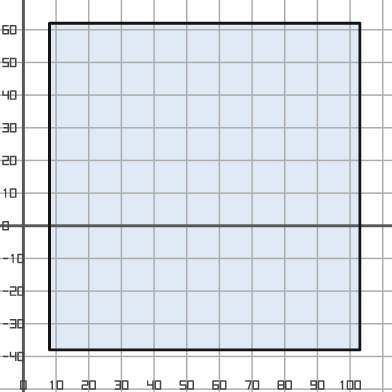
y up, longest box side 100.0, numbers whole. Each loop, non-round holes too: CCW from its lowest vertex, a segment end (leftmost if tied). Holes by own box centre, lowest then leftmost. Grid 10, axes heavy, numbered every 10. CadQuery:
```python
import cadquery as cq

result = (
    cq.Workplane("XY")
    .moveTo(8.0, -38.0)
    .lineTo(103.0, -38.0)
    .lineTo(103.0, 62.0)
    .lineTo(8.0, 62.0)
    .close()
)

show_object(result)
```